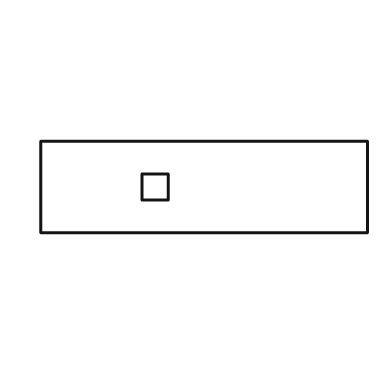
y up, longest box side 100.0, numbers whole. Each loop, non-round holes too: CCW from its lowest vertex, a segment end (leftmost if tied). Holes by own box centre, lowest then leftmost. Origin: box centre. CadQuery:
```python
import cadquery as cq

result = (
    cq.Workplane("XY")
    .moveTo(-50.0, -14.0)
    .lineTo(50.0, -14.0)
    .lineTo(50.0, 14.0)
    .lineTo(-50.0, 14.0)
    .close()
    .moveTo(-19.0, -4.0)
    .lineTo(-11.0, -4.0)
    .lineTo(-11.0, 4.0)
    .lineTo(-19.0, 4.0)
    .close()
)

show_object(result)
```